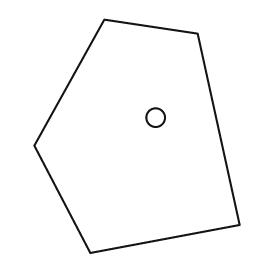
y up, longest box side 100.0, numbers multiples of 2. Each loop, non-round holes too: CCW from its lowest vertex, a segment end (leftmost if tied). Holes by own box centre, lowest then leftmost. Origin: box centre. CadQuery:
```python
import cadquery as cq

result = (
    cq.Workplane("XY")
    .moveTo(-20.0, -50.0)
    .lineTo(44.0, -38.0)
    .lineTo(26.0, 44.0)
    .lineTo(-14.0, 50.0)
    .lineTo(-44.0, -4.0)
    .close()
    .moveTo(8.0, 8.0)
    .circle(4.0)
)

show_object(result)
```